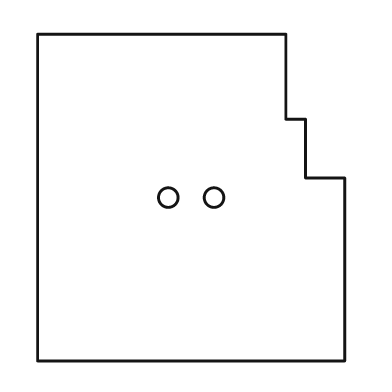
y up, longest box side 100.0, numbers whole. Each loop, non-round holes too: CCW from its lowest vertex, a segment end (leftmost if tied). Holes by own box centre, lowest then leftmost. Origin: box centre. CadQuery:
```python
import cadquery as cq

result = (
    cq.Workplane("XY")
    .moveTo(-47.0, -50.0)
    .lineTo(47.0, -50.0)
    .lineTo(47.0, 6.0)
    .lineTo(35.0, 6.0)
    .lineTo(35.0, 24.0)
    .lineTo(29.0, 24.0)
    .lineTo(29.0, 50.0)
    .lineTo(-47.0, 50.0)
    .close()
    .moveTo(-7.0, 0.0)
    .circle(3.0)
    .moveTo(7.0, 0.0)
    .circle(3.0)
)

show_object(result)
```